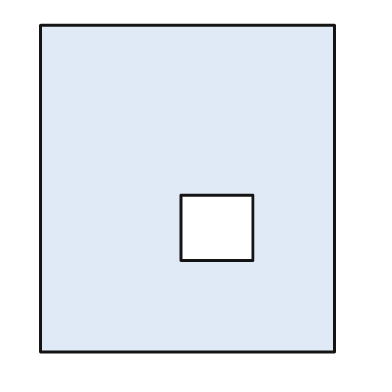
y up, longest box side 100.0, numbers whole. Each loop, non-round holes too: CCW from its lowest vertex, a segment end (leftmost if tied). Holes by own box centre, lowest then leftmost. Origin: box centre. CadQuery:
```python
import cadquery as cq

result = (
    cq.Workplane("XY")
    .moveTo(-45.0, -50.0)
    .lineTo(45.0, -50.0)
    .lineTo(45.0, 50.0)
    .lineTo(-45.0, 50.0)
    .close()
    .moveTo(-2.0, -22.0)
    .lineTo(20.0, -22.0)
    .lineTo(20.0, -2.0)
    .lineTo(-2.0, -2.0)
    .close()
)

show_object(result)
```